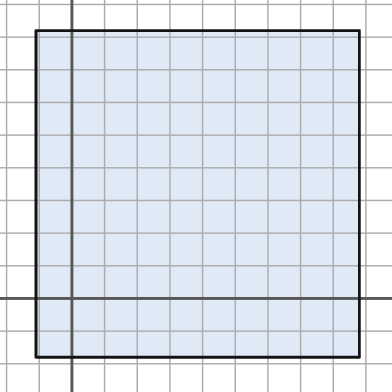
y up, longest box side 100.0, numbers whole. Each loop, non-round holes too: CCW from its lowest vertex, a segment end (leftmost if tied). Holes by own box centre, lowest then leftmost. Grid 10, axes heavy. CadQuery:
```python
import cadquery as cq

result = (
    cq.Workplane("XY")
    .moveTo(-11.0, -18.0)
    .lineTo(88.0, -18.0)
    .lineTo(88.0, 82.0)
    .lineTo(-11.0, 82.0)
    .close()
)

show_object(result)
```